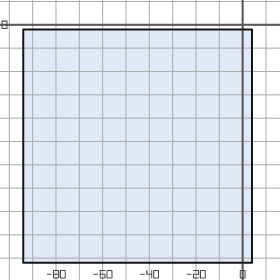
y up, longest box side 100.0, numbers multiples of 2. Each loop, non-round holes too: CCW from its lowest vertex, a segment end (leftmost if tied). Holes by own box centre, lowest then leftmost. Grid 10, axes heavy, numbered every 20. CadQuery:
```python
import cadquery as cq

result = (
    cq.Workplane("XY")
    .moveTo(-94.0, -102.0)
    .lineTo(4.0, -102.0)
    .lineTo(4.0, -2.0)
    .lineTo(-94.0, -2.0)
    .close()
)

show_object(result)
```